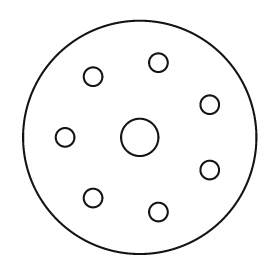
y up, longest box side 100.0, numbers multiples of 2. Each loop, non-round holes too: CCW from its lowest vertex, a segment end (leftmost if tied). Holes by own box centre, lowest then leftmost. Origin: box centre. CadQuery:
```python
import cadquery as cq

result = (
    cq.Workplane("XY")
    .moveTo(0.0, 0.0)
    .circle(50.0)
    .moveTo(8.0, -32.0)
    .circle(4.0)
    .moveTo(-20.0, -26.0)
    .circle(4.0)
    .moveTo(30.0, -14.0)
    .circle(4.0)
    .moveTo(-32.0, 0.0)
    .circle(4.0)
    .moveTo(0.0, 0.0)
    .circle(8.0)
    .moveTo(30.0, 14.0)
    .circle(4.0)
    .moveTo(-20.0, 26.0)
    .circle(4.0)
    .moveTo(8.0, 32.0)
    .circle(4.0)
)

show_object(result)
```